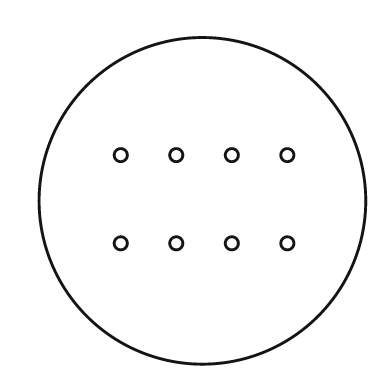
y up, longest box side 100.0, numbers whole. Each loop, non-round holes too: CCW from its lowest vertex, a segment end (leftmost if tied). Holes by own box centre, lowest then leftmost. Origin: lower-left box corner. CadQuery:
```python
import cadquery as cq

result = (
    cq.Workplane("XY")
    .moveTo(50.0, 50.0)
    .circle(50.0)
    .moveTo(25.0, 37.0)
    .circle(2.0)
    .moveTo(42.0, 37.0)
    .circle(2.0)
    .moveTo(59.0, 37.0)
    .circle(2.0)
    .moveTo(76.0, 37.0)
    .circle(2.0)
    .moveTo(25.0, 64.0)
    .circle(2.0)
    .moveTo(42.0, 64.0)
    .circle(2.0)
    .moveTo(59.0, 64.0)
    .circle(2.0)
    .moveTo(76.0, 64.0)
    .circle(2.0)
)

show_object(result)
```